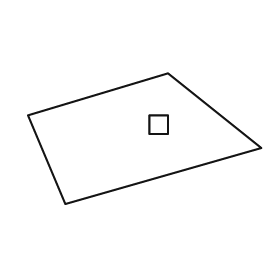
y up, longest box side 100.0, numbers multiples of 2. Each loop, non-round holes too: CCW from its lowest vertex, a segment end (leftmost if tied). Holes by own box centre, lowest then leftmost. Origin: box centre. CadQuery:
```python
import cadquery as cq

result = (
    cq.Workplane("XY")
    .moveTo(-34.0, -28.0)
    .lineTo(50.0, -4.0)
    .lineTo(10.0, 28.0)
    .lineTo(-50.0, 10.0)
    .close()
    .moveTo(2.0, 2.0)
    .lineTo(10.0, 2.0)
    .lineTo(10.0, 10.0)
    .lineTo(2.0, 10.0)
    .close()
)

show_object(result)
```